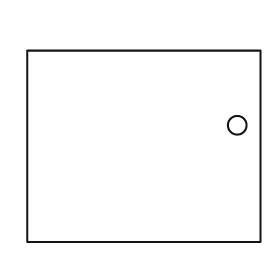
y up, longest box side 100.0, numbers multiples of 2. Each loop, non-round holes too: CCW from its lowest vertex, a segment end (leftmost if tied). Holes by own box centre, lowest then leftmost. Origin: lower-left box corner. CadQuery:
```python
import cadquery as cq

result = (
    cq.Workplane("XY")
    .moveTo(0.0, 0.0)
    .lineTo(100.0, 0.0)
    .lineTo(100.0, 82.0)
    .lineTo(0.0, 82.0)
    .close()
    .moveTo(90.0, 50.0)
    .circle(4.0)
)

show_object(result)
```